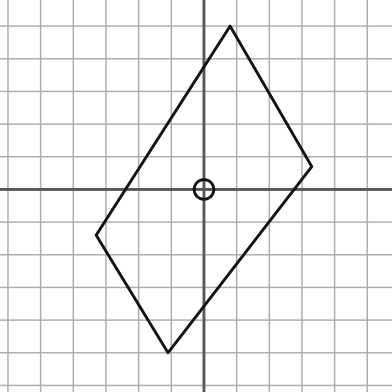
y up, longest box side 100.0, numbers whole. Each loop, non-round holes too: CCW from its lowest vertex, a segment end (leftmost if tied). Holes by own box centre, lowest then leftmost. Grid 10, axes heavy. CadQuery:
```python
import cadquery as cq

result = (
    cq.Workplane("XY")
    .moveTo(-11.0, -50.0)
    .lineTo(33.0, 7.0)
    .lineTo(8.0, 50.0)
    .lineTo(-33.0, -14.0)
    .close()
    .moveTo(0.0, 0.0)
    .circle(3.0)
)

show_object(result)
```